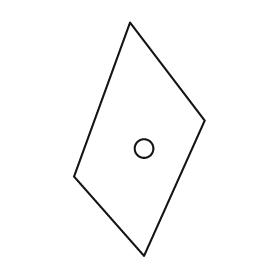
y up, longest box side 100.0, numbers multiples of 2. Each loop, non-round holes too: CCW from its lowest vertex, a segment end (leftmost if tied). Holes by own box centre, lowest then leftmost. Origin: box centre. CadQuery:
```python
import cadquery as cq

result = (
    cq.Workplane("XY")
    .moveTo(2.0, -50.0)
    .lineTo(28.0, 8.0)
    .lineTo(-4.0, 50.0)
    .lineTo(-28.0, -16.0)
    .close()
    .moveTo(2.0, -4.0)
    .circle(4.0)
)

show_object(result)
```